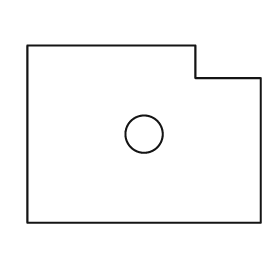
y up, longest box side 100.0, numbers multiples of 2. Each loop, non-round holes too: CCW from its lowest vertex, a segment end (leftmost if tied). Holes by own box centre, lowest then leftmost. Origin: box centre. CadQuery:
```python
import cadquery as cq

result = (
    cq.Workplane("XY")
    .moveTo(-50.0, -38.0)
    .lineTo(50.0, -38.0)
    .lineTo(50.0, 24.0)
    .lineTo(22.0, 24.0)
    .lineTo(22.0, 38.0)
    .lineTo(-50.0, 38.0)
    .close()
    .moveTo(0.0, 0.0)
    .circle(8.0)
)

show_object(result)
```